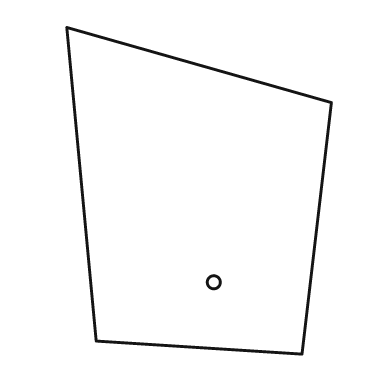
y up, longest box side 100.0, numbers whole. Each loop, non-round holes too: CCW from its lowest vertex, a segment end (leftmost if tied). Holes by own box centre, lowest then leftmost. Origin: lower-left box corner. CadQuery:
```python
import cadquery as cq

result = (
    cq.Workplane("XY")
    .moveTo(72.0, 0.0)
    .lineTo(81.0, 77.0)
    .lineTo(0.0, 100.0)
    .lineTo(9.0, 4.0)
    .close()
    .moveTo(45.0, 22.0)
    .circle(2.0)
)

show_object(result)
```